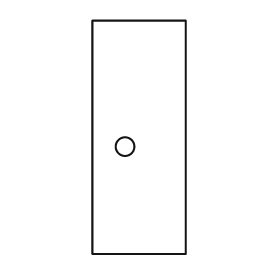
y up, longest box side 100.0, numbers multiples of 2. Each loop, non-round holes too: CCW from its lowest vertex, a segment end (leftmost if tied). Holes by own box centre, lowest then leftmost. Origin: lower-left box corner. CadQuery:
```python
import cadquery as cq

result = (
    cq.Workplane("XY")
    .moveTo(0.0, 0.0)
    .lineTo(40.0, 0.0)
    .lineTo(40.0, 100.0)
    .lineTo(0.0, 100.0)
    .close()
    .moveTo(14.0, 46.0)
    .circle(4.0)
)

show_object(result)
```